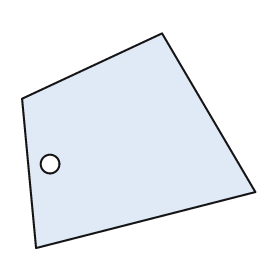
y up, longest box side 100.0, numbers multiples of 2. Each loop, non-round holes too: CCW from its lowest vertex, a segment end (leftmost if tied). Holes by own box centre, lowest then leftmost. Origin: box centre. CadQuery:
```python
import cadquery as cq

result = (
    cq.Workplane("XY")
    .moveTo(-44.0, -46.0)
    .lineTo(50.0, -22.0)
    .lineTo(10.0, 46.0)
    .lineTo(-50.0, 18.0)
    .close()
    .moveTo(-38.0, -10.0)
    .circle(4.0)
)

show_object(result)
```